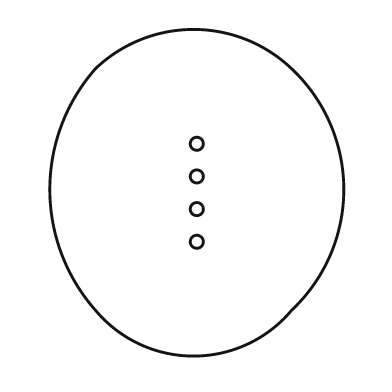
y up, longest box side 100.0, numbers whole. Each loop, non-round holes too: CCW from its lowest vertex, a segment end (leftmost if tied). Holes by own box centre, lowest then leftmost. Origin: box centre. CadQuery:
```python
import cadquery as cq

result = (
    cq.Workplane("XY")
    .moveTo(-31.0, -36.0)
    .threePointArc((-1.0, -50.0), (29.0, -36.0))
    .threePointArc((45.0, 1.0), (29.0, 38.0))
    .threePointArc((-1.0, 50.0), (-31.0, 38.0))
    .threePointArc((-45.0, 1.0), (-31.0, -36.0))
    .close()
    .moveTo(0.0, -15.0)
    .circle(2.0)
    .moveTo(0.0, -5.0)
    .circle(2.0)
    .moveTo(0.0, 5.0)
    .circle(2.0)
    .moveTo(0.0, 15.0)
    .circle(2.0)
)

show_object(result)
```